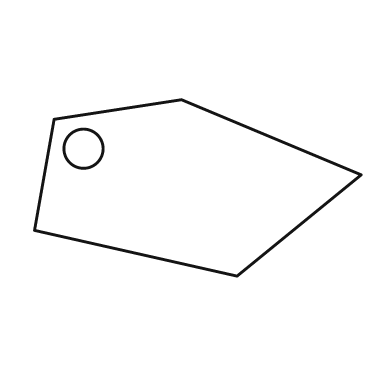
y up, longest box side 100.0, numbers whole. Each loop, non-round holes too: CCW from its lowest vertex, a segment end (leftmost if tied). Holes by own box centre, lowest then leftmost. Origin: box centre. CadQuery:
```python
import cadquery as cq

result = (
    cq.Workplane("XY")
    .moveTo(12.0, -27.0)
    .lineTo(50.0, 4.0)
    .lineTo(-5.0, 27.0)
    .lineTo(-44.0, 21.0)
    .lineTo(-50.0, -13.0)
    .close()
    .moveTo(-35.0, 12.0)
    .circle(6.0)
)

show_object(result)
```